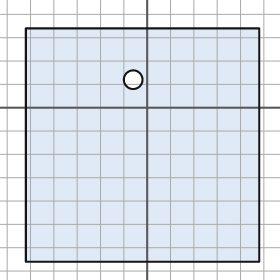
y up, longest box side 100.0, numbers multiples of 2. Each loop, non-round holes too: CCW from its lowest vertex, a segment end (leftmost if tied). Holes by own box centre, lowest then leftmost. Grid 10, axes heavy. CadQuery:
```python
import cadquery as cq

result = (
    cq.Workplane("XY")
    .moveTo(-52.0, -66.0)
    .lineTo(48.0, -66.0)
    .lineTo(48.0, 34.0)
    .lineTo(-52.0, 34.0)
    .close()
    .moveTo(-6.0, 12.0)
    .circle(4.0)
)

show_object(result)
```